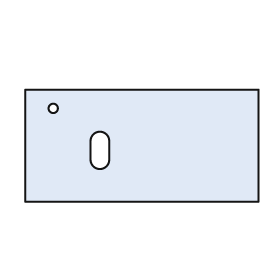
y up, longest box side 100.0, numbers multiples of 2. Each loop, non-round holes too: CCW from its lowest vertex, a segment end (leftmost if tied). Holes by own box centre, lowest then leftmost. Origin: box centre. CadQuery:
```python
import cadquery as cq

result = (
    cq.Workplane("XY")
    .moveTo(-50.0, -24.0)
    .lineTo(50.0, -24.0)
    .lineTo(50.0, 24.0)
    .lineTo(-50.0, 24.0)
    .close()
    .moveTo(-22.0, -6.0)
    .threePointArc((-18.0, -10.0), (-14.0, -6.0))
    .lineTo(-14.0, 2.0)
    .threePointArc((-18.0, 6.0), (-22.0, 2.0))
    .close()
    .moveTo(-38.0, 16.0)
    .circle(2.0)
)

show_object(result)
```